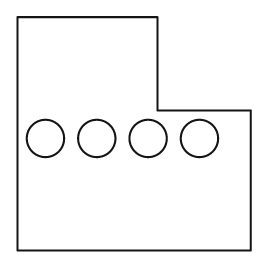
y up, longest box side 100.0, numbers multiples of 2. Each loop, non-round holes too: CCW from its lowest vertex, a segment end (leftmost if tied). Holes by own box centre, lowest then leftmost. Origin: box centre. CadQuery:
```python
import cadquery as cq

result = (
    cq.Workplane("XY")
    .moveTo(-50.0, -50.0)
    .lineTo(50.0, -50.0)
    .lineTo(50.0, 10.0)
    .lineTo(10.0, 10.0)
    .lineTo(10.0, 50.0)
    .lineTo(-50.0, 50.0)
    .close()
    .moveTo(-38.0, -2.0)
    .circle(8.0)
    .moveTo(-16.0, -2.0)
    .circle(8.0)
    .moveTo(6.0, -2.0)
    .circle(8.0)
    .moveTo(28.0, -2.0)
    .circle(8.0)
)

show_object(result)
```